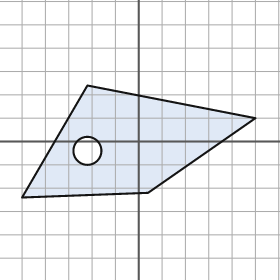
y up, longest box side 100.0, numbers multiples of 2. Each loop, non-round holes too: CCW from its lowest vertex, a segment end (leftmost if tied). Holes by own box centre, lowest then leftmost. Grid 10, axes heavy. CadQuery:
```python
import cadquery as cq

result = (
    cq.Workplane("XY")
    .moveTo(-50.0, -24.0)
    .lineTo(4.0, -22.0)
    .lineTo(50.0, 10.0)
    .lineTo(-22.0, 24.0)
    .close()
    .moveTo(-22.0, -4.0)
    .circle(6.0)
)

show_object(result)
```